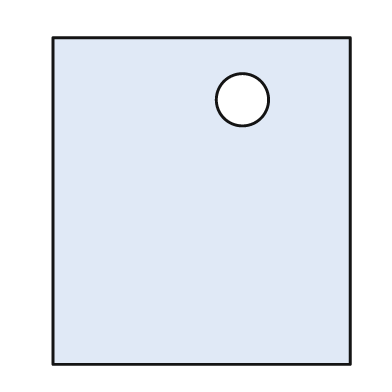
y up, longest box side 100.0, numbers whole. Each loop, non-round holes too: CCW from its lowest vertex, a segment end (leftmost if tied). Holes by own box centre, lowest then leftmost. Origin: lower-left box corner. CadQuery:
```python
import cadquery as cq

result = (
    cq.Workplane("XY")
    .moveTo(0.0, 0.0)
    .lineTo(91.0, 0.0)
    .lineTo(91.0, 100.0)
    .lineTo(0.0, 100.0)
    .close()
    .moveTo(58.0, 81.0)
    .circle(8.0)
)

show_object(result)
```